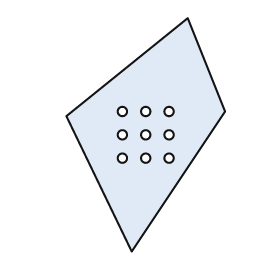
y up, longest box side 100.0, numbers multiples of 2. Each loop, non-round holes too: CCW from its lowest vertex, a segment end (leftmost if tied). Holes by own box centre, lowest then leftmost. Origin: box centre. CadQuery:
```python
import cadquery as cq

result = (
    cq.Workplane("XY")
    .moveTo(-6.0, -50.0)
    .lineTo(34.0, 10.0)
    .lineTo(18.0, 50.0)
    .lineTo(-34.0, 8.0)
    .close()
    .moveTo(-10.0, -10.0)
    .circle(2.0)
    .moveTo(0.0, -10.0)
    .circle(2.0)
    .moveTo(10.0, -10.0)
    .circle(2.0)
    .moveTo(-10.0, 0.0)
    .circle(2.0)
    .moveTo(0.0, 0.0)
    .circle(2.0)
    .moveTo(10.0, 0.0)
    .circle(2.0)
    .moveTo(-10.0, 10.0)
    .circle(2.0)
    .moveTo(0.0, 10.0)
    .circle(2.0)
    .moveTo(10.0, 10.0)
    .circle(2.0)
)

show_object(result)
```